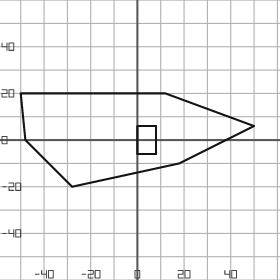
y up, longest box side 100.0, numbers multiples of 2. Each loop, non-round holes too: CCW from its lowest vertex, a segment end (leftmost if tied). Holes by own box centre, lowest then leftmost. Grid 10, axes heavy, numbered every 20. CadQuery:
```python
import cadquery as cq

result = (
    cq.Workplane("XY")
    .moveTo(-28.0, -20.0)
    .lineTo(18.0, -10.0)
    .lineTo(50.0, 6.0)
    .lineTo(12.0, 20.0)
    .lineTo(-50.0, 20.0)
    .lineTo(-48.0, 0.0)
    .close()
    .moveTo(0.0, -6.0)
    .lineTo(8.0, -6.0)
    .lineTo(8.0, 6.0)
    .lineTo(0.0, 6.0)
    .close()
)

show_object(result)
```